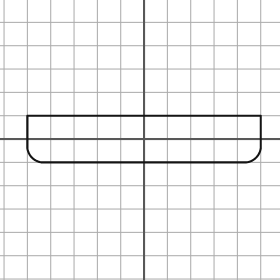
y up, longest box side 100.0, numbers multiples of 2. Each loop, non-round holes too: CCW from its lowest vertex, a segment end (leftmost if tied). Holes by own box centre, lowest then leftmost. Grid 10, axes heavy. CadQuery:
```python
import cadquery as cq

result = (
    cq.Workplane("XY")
    .moveTo(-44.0, -10.0)
    .lineTo(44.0, -10.0)
    .threePointArc((48.0, -8.0), (50.0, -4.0))
    .lineTo(50.0, 10.0)
    .lineTo(-50.0, 10.0)
    .lineTo(-50.0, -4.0)
    .threePointArc((-48.0, -8.0), (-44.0, -10.0))
    .close()
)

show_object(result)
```